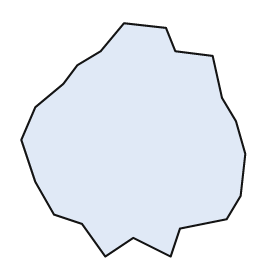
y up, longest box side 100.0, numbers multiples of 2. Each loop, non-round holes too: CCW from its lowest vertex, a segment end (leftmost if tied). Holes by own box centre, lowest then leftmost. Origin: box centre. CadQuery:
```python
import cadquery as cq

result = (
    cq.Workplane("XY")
    .moveTo(-12.0, -50.0)
    .lineTo(0.0, -42.0)
    .lineTo(16.0, -50.0)
    .lineTo(20.0, -38.0)
    .lineTo(40.0, -34.0)
    .lineTo(46.0, -24.0)
    .lineTo(48.0, -6.0)
    .lineTo(44.0, 8.0)
    .lineTo(38.0, 18.0)
    .lineTo(34.0, 36.0)
    .lineTo(18.0, 38.0)
    .lineTo(14.0, 48.0)
    .lineTo(-4.0, 50.0)
    .lineTo(-14.0, 38.0)
    .lineTo(-24.0, 32.0)
    .lineTo(-30.0, 24.0)
    .lineTo(-42.0, 14.0)
    .lineTo(-48.0, 0.0)
    .lineTo(-42.0, -18.0)
    .lineTo(-34.0, -32.0)
    .lineTo(-22.0, -36.0)
    .close()
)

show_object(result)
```